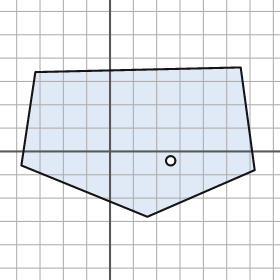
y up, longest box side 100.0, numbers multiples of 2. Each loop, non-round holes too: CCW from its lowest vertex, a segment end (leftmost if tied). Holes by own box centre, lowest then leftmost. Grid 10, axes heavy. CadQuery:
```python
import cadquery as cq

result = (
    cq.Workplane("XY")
    .moveTo(16.0, -28.0)
    .lineTo(62.0, -8.0)
    .lineTo(56.0, 36.0)
    .lineTo(-32.0, 34.0)
    .lineTo(-38.0, -6.0)
    .close()
    .moveTo(26.0, -4.0)
    .circle(2.0)
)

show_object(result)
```